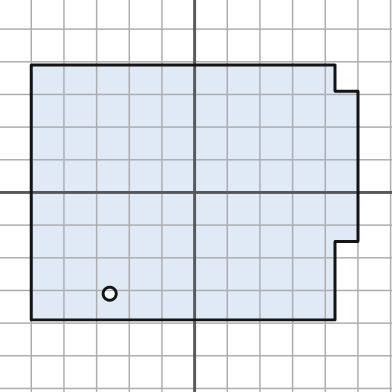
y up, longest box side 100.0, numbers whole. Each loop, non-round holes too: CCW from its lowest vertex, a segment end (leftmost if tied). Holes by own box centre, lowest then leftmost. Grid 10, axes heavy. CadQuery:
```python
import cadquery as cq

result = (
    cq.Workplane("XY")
    .moveTo(-50.0, -39.0)
    .lineTo(43.0, -39.0)
    .lineTo(43.0, -15.0)
    .lineTo(50.0, -15.0)
    .lineTo(50.0, 31.0)
    .lineTo(43.0, 31.0)
    .lineTo(43.0, 39.0)
    .lineTo(-50.0, 39.0)
    .close()
    .moveTo(-26.0, -31.0)
    .circle(2.0)
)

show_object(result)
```